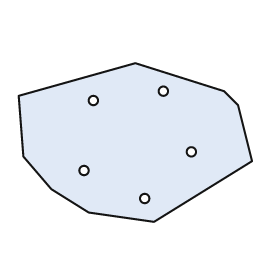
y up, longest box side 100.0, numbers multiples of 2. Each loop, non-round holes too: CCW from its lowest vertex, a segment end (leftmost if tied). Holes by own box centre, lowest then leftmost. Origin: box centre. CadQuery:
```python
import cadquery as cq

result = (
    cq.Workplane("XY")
    .moveTo(8.0, -34.0)
    .lineTo(50.0, -8.0)
    .lineTo(44.0, 16.0)
    .lineTo(38.0, 22.0)
    .lineTo(0.0, 34.0)
    .lineTo(-50.0, 20.0)
    .lineTo(-48.0, -6.0)
    .lineTo(-36.0, -20.0)
    .lineTo(-20.0, -30.0)
    .close()
    .moveTo(4.0, -24.0)
    .circle(2.0)
    .moveTo(-22.0, -12.0)
    .circle(2.0)
    .moveTo(24.0, -4.0)
    .circle(2.0)
    .moveTo(-18.0, 18.0)
    .circle(2.0)
    .moveTo(12.0, 22.0)
    .circle(2.0)
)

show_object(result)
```